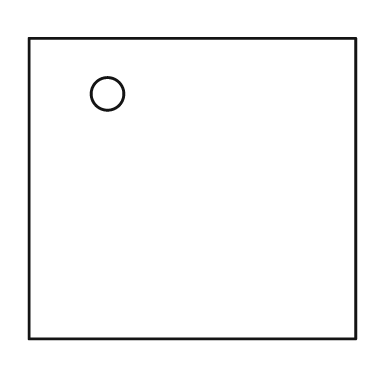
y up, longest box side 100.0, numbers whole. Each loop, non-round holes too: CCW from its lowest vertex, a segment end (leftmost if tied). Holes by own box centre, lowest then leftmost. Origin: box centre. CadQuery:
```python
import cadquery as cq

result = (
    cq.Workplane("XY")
    .moveTo(-50.0, -46.0)
    .lineTo(50.0, -46.0)
    .lineTo(50.0, 46.0)
    .lineTo(-50.0, 46.0)
    .close()
    .moveTo(-26.0, 29.0)
    .circle(5.0)
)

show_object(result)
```